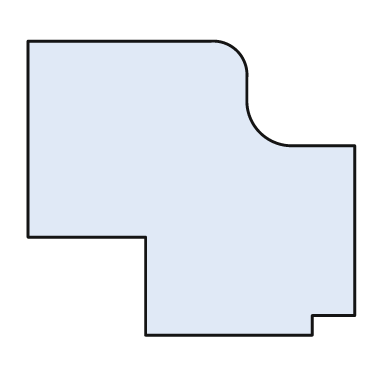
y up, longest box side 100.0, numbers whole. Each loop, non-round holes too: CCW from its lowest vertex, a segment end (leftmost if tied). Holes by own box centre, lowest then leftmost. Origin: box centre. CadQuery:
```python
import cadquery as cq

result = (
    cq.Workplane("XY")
    .moveTo(-14.0, -45.0)
    .lineTo(37.0, -45.0)
    .lineTo(37.0, -39.0)
    .lineTo(50.0, -39.0)
    .lineTo(50.0, 13.0)
    .lineTo(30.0, 13.0)
    .threePointArc((21.0, 17.0), (17.0, 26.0))
    .lineTo(17.0, 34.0)
    .threePointArc((14.0, 42.0), (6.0, 45.0))
    .lineTo(-50.0, 45.0)
    .lineTo(-50.0, -15.0)
    .lineTo(-14.0, -15.0)
    .close()
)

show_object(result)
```